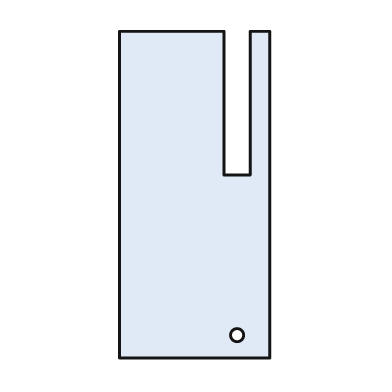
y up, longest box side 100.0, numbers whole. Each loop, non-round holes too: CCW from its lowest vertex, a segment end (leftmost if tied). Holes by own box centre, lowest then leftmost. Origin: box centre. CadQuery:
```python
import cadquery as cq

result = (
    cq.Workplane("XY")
    .moveTo(-23.0, -50.0)
    .lineTo(23.0, -50.0)
    .lineTo(23.0, 50.0)
    .lineTo(17.0, 50.0)
    .lineTo(17.0, 6.0)
    .lineTo(9.0, 6.0)
    .lineTo(9.0, 50.0)
    .lineTo(-23.0, 50.0)
    .close()
    .moveTo(13.0, -43.0)
    .circle(2.0)
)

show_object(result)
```